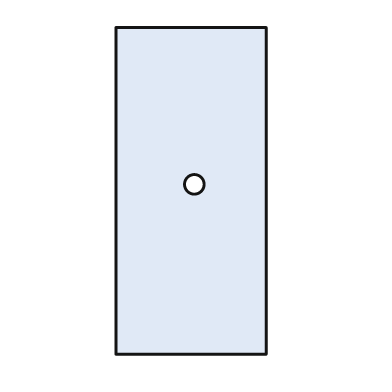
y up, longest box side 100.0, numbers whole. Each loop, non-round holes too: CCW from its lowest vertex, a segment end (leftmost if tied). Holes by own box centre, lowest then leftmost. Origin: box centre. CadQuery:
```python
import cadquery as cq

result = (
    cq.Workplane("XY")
    .moveTo(-23.0, -50.0)
    .lineTo(23.0, -50.0)
    .lineTo(23.0, 50.0)
    .lineTo(-23.0, 50.0)
    .close()
    .moveTo(1.0, 2.0)
    .circle(3.0)
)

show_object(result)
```